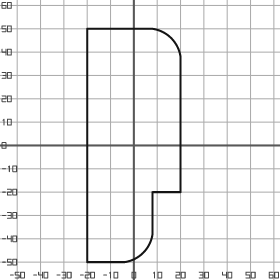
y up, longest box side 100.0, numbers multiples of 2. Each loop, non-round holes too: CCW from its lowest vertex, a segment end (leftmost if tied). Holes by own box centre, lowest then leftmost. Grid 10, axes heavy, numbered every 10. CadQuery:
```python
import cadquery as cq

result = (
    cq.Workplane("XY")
    .moveTo(-20.0, -50.0)
    .lineTo(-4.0, -50.0)
    .threePointArc((4.0, -46.0), (8.0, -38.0))
    .lineTo(8.0, -20.0)
    .lineTo(20.0, -20.0)
    .lineTo(20.0, 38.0)
    .threePointArc((16.0, 46.0), (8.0, 50.0))
    .lineTo(-20.0, 50.0)
    .close()
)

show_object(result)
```